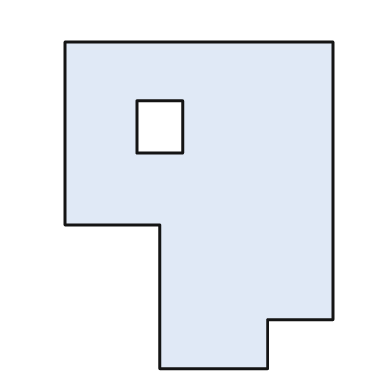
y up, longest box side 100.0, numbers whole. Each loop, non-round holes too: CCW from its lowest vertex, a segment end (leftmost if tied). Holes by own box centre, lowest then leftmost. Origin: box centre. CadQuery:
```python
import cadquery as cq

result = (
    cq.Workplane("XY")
    .moveTo(-12.0, -50.0)
    .lineTo(21.0, -50.0)
    .lineTo(21.0, -35.0)
    .lineTo(41.0, -35.0)
    .lineTo(41.0, 50.0)
    .lineTo(-41.0, 50.0)
    .lineTo(-41.0, -6.0)
    .lineTo(-12.0, -6.0)
    .close()
    .moveTo(-19.0, 16.0)
    .lineTo(-5.0, 16.0)
    .lineTo(-5.0, 32.0)
    .lineTo(-19.0, 32.0)
    .close()
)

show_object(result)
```